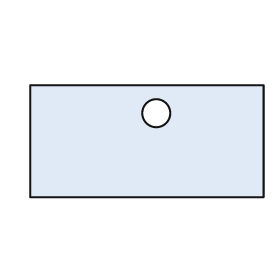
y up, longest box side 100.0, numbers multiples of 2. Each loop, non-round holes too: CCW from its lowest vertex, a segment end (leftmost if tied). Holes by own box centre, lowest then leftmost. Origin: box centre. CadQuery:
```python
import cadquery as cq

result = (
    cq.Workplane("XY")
    .moveTo(-50.0, -24.0)
    .lineTo(50.0, -24.0)
    .lineTo(50.0, 24.0)
    .lineTo(-50.0, 24.0)
    .close()
    .moveTo(4.0, 12.0)
    .circle(6.0)
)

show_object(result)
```